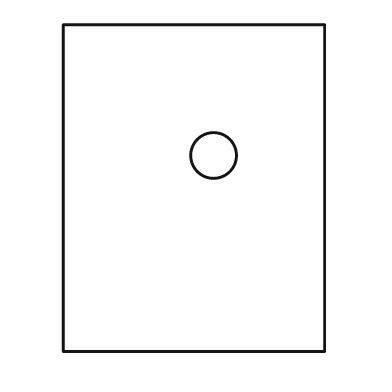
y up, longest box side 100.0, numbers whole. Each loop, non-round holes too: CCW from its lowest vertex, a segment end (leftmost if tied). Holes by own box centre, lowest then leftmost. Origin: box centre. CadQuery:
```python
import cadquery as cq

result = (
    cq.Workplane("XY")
    .moveTo(-40.0, -50.0)
    .lineTo(40.0, -50.0)
    .lineTo(40.0, 50.0)
    .lineTo(-40.0, 50.0)
    .close()
    .moveTo(6.0, 10.0)
    .circle(7.0)
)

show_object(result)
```